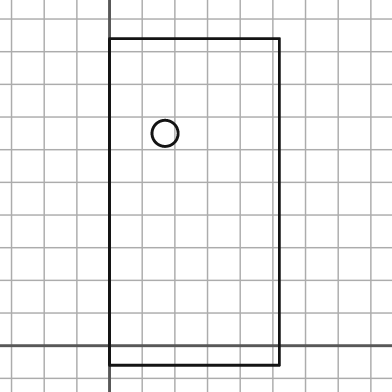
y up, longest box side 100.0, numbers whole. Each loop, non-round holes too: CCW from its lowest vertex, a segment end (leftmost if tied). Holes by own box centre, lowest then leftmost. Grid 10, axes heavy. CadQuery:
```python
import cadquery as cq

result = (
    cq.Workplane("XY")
    .moveTo(0.0, -6.0)
    .lineTo(52.0, -6.0)
    .lineTo(52.0, 94.0)
    .lineTo(0.0, 94.0)
    .close()
    .moveTo(17.0, 65.0)
    .circle(4.0)
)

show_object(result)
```